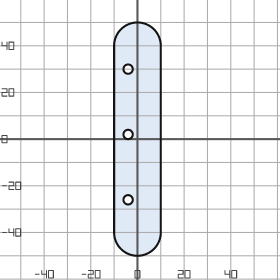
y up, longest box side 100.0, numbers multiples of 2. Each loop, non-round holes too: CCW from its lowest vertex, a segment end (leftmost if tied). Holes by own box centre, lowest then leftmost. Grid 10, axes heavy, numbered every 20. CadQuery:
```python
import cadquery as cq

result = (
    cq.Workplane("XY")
    .moveTo(-10.0, -40.0)
    .threePointArc((0.0, -50.0), (10.0, -40.0))
    .lineTo(10.0, 40.0)
    .threePointArc((0.0, 50.0), (-10.0, 40.0))
    .close()
    .moveTo(-4.0, -26.0)
    .circle(2.0)
    .moveTo(-4.0, 2.0)
    .circle(2.0)
    .moveTo(-4.0, 30.0)
    .circle(2.0)
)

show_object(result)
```